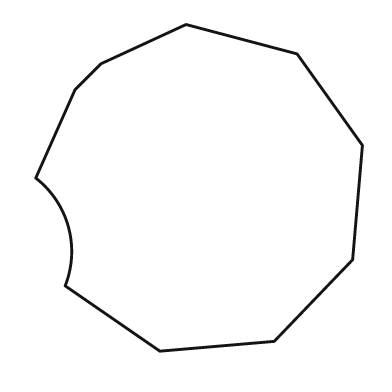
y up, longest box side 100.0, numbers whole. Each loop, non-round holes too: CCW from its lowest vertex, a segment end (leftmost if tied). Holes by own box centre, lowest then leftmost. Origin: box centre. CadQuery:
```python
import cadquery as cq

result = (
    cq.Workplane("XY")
    .moveTo(-12.0, -50.0)
    .lineTo(23.0, -47.0)
    .lineTo(47.0, -22.0)
    .lineTo(50.0, 13.0)
    .lineTo(30.0, 41.0)
    .lineTo(-4.0, 50.0)
    .lineTo(-30.0, 38.0)
    .lineTo(-38.0, 30.0)
    .lineTo(-50.0, 3.0)
    .threePointArc((-40.0, -12.0), (-41.0, -30.0))
    .close()
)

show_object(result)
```